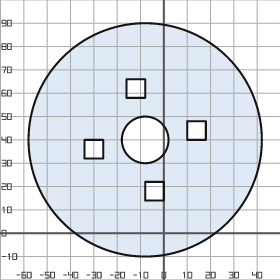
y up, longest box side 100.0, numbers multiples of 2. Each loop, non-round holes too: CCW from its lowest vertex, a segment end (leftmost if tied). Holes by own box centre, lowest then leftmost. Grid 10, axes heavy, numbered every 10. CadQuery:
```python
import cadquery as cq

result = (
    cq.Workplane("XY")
    .moveTo(-8.0, 40.0)
    .circle(50.0)
    .moveTo(-8.0, 14.0)
    .lineTo(0.0, 14.0)
    .lineTo(0.0, 22.0)
    .lineTo(-8.0, 22.0)
    .close()
    .moveTo(-34.0, 32.0)
    .lineTo(-26.0, 32.0)
    .lineTo(-26.0, 40.0)
    .lineTo(-34.0, 40.0)
    .close()
    .moveTo(-8.0, 40.0)
    .circle(10.0)
    .moveTo(10.0, 40.0)
    .lineTo(18.0, 40.0)
    .lineTo(18.0, 48.0)
    .lineTo(10.0, 48.0)
    .close()
    .moveTo(-16.0, 58.0)
    .lineTo(-8.0, 58.0)
    .lineTo(-8.0, 66.0)
    .lineTo(-16.0, 66.0)
    .close()
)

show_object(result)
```